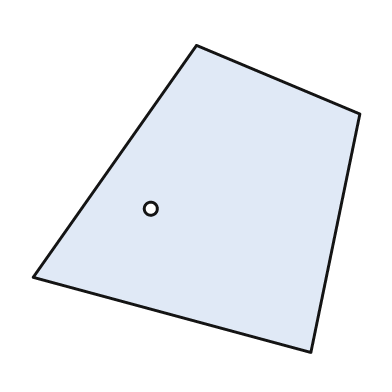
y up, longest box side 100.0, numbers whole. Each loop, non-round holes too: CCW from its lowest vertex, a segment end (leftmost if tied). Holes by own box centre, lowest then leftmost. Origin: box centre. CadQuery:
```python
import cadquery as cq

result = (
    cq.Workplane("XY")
    .moveTo(35.0, -47.0)
    .lineTo(50.0, 26.0)
    .lineTo(0.0, 47.0)
    .lineTo(-50.0, -24.0)
    .close()
    .moveTo(-14.0, -3.0)
    .circle(2.0)
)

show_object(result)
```